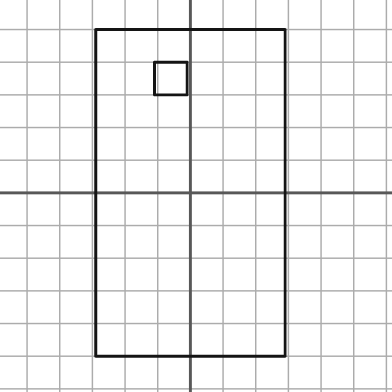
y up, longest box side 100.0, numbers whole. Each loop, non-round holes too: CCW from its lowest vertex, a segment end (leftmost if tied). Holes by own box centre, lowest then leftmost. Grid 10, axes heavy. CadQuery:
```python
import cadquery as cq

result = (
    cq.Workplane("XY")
    .moveTo(-29.0, -50.0)
    .lineTo(29.0, -50.0)
    .lineTo(29.0, 50.0)
    .lineTo(-29.0, 50.0)
    .close()
    .moveTo(-11.0, 30.0)
    .lineTo(-1.0, 30.0)
    .lineTo(-1.0, 40.0)
    .lineTo(-11.0, 40.0)
    .close()
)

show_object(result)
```